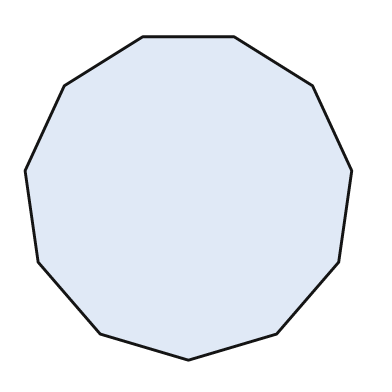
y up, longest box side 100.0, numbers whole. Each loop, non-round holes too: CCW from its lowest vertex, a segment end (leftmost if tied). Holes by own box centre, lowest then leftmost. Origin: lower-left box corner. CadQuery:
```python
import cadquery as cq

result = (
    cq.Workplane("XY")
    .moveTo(50.0, 0.0)
    .lineTo(77.0, 8.0)
    .lineTo(96.0, 30.0)
    .lineTo(100.0, 58.0)
    .lineTo(88.0, 84.0)
    .lineTo(64.0, 99.0)
    .lineTo(36.0, 99.0)
    .lineTo(12.0, 84.0)
    .lineTo(0.0, 58.0)
    .lineTo(4.0, 30.0)
    .lineTo(23.0, 8.0)
    .close()
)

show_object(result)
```